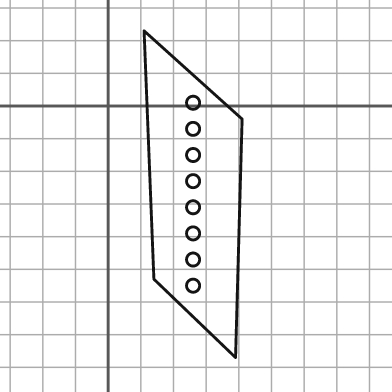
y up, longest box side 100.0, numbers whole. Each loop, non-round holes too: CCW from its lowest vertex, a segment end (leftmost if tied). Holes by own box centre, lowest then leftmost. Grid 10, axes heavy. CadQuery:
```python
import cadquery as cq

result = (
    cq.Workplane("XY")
    .moveTo(39.0, -77.0)
    .lineTo(41.0, -4.0)
    .lineTo(11.0, 23.0)
    .lineTo(14.0, -53.0)
    .close()
    .moveTo(26.0, -55.0)
    .circle(2.0)
    .moveTo(26.0, -47.0)
    .circle(2.0)
    .moveTo(26.0, -39.0)
    .circle(2.0)
    .moveTo(26.0, -31.0)
    .circle(2.0)
    .moveTo(26.0, -23.0)
    .circle(2.0)
    .moveTo(26.0, -15.0)
    .circle(2.0)
    .moveTo(26.0, -7.0)
    .circle(2.0)
    .moveTo(26.0, 1.0)
    .circle(2.0)
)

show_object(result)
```